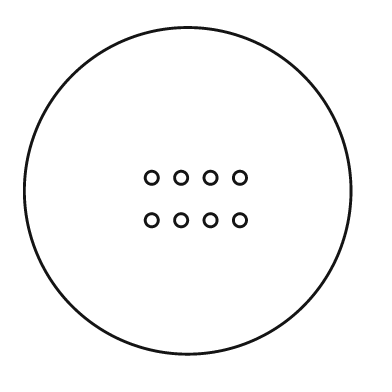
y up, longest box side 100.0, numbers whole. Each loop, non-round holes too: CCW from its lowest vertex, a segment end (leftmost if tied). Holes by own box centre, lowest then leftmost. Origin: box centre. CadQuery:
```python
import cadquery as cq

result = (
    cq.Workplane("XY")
    .moveTo(0.0, 0.0)
    .circle(50.0)
    .moveTo(-11.0, -9.0)
    .circle(2.0)
    .moveTo(-2.0, -9.0)
    .circle(2.0)
    .moveTo(7.0, -9.0)
    .circle(2.0)
    .moveTo(16.0, -9.0)
    .circle(2.0)
    .moveTo(-11.0, 4.0)
    .circle(2.0)
    .moveTo(-2.0, 4.0)
    .circle(2.0)
    .moveTo(7.0, 4.0)
    .circle(2.0)
    .moveTo(16.0, 4.0)
    .circle(2.0)
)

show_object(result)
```